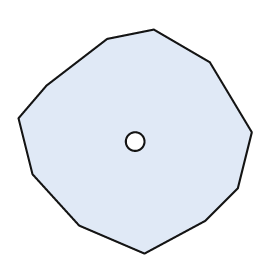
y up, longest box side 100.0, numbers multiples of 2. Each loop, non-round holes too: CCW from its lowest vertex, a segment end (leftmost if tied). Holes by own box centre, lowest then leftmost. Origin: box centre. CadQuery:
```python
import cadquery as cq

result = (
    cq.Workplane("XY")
    .moveTo(4.0, -48.0)
    .lineTo(30.0, -34.0)
    .lineTo(44.0, -20.0)
    .lineTo(50.0, 4.0)
    .lineTo(32.0, 34.0)
    .lineTo(8.0, 48.0)
    .lineTo(-12.0, 44.0)
    .lineTo(-38.0, 24.0)
    .lineTo(-50.0, 10.0)
    .lineTo(-44.0, -14.0)
    .lineTo(-24.0, -36.0)
    .close()
    .moveTo(0.0, 0.0)
    .circle(4.0)
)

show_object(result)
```